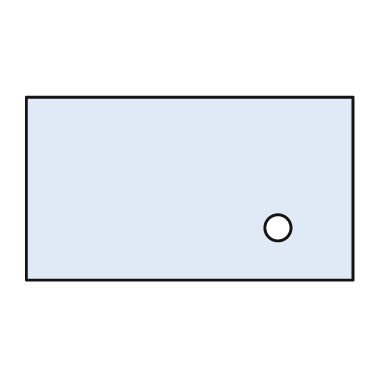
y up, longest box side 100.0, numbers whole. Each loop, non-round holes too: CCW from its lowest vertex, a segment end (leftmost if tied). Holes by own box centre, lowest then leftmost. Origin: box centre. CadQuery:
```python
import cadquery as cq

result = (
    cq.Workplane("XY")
    .moveTo(-50.0, -28.0)
    .lineTo(50.0, -28.0)
    .lineTo(50.0, 28.0)
    .lineTo(-50.0, 28.0)
    .close()
    .moveTo(27.0, -12.0)
    .circle(4.0)
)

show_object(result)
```